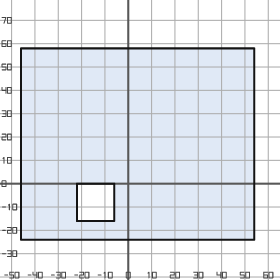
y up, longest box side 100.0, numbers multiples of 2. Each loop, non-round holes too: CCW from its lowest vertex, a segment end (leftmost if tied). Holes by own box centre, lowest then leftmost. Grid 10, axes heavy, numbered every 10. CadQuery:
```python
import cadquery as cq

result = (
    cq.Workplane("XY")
    .moveTo(-46.0, -24.0)
    .lineTo(54.0, -24.0)
    .lineTo(54.0, 58.0)
    .lineTo(-46.0, 58.0)
    .close()
    .moveTo(-22.0, -16.0)
    .lineTo(-6.0, -16.0)
    .lineTo(-6.0, 0.0)
    .lineTo(-22.0, 0.0)
    .close()
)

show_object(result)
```